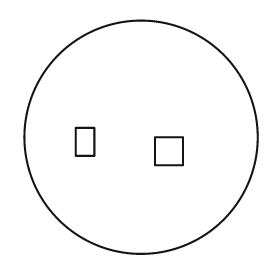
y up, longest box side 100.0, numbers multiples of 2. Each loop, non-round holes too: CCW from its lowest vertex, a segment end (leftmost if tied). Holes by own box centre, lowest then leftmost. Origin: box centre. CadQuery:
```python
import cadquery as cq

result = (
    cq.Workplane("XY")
    .moveTo(0.0, 0.0)
    .circle(50.0)
    .moveTo(6.0, -12.0)
    .lineTo(18.0, -12.0)
    .lineTo(18.0, 0.0)
    .lineTo(6.0, 0.0)
    .close()
    .moveTo(-28.0, -8.0)
    .lineTo(-20.0, -8.0)
    .lineTo(-20.0, 4.0)
    .lineTo(-28.0, 4.0)
    .close()
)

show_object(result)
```